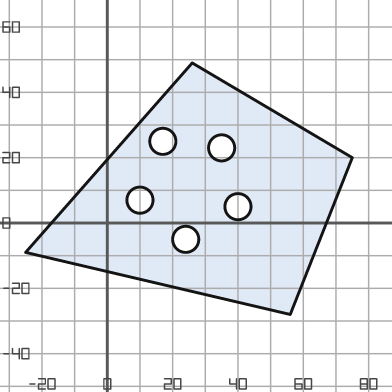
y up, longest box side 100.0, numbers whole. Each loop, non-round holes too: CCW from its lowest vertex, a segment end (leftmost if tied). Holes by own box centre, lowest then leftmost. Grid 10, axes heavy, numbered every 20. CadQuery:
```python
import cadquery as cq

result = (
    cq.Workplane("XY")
    .moveTo(56.0, -28.0)
    .lineTo(75.0, 20.0)
    .lineTo(26.0, 49.0)
    .lineTo(-25.0, -9.0)
    .close()
    .moveTo(24.0, -5.0)
    .circle(4.0)
    .moveTo(40.0, 5.0)
    .circle(4.0)
    .moveTo(10.0, 7.0)
    .circle(4.0)
    .moveTo(35.0, 23.0)
    .circle(4.0)
    .moveTo(17.0, 25.0)
    .circle(4.0)
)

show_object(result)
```